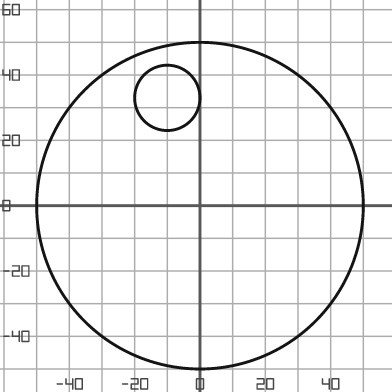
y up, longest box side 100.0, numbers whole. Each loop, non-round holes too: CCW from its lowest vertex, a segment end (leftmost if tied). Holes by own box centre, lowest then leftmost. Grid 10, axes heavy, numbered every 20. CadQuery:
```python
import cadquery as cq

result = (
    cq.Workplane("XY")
    .moveTo(0.0, 0.0)
    .circle(50.0)
    .moveTo(-10.0, 33.0)
    .circle(10.0)
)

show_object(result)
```